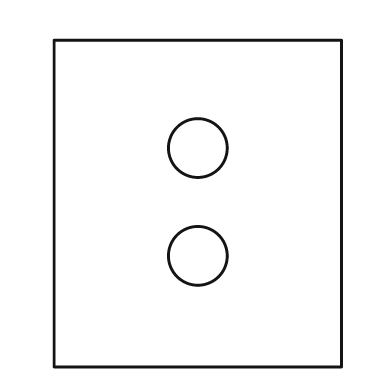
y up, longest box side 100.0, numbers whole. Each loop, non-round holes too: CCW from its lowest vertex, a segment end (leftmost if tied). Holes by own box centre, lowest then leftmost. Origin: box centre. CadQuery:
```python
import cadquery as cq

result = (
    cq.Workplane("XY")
    .moveTo(-44.0, -50.0)
    .lineTo(44.0, -50.0)
    .lineTo(44.0, 50.0)
    .lineTo(-44.0, 50.0)
    .close()
    .moveTo(0.0, -16.0)
    .circle(9.0)
    .moveTo(0.0, 17.0)
    .circle(9.0)
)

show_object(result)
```